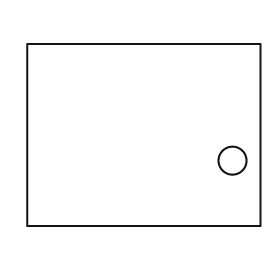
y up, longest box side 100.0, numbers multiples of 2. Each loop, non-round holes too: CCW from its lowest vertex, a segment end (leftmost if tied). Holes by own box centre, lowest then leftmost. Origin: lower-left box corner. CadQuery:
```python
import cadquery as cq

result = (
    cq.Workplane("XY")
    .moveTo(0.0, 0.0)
    .lineTo(100.0, 0.0)
    .lineTo(100.0, 78.0)
    .lineTo(0.0, 78.0)
    .close()
    .moveTo(88.0, 28.0)
    .circle(6.0)
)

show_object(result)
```